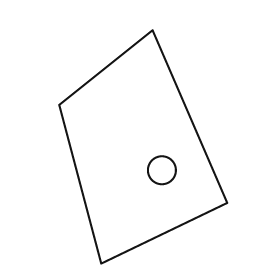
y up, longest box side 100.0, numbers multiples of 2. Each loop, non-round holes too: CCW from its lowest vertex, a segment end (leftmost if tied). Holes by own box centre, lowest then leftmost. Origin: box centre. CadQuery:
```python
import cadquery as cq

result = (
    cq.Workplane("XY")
    .moveTo(-18.0, -50.0)
    .lineTo(36.0, -24.0)
    .lineTo(4.0, 50.0)
    .lineTo(-36.0, 18.0)
    .close()
    .moveTo(8.0, -10.0)
    .circle(6.0)
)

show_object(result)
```